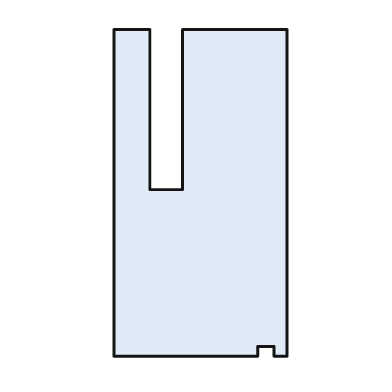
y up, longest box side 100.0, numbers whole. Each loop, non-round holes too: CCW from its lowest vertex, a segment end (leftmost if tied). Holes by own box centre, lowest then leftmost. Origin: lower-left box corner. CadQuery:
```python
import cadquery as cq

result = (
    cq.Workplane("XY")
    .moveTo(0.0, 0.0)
    .lineTo(44.0, 0.0)
    .lineTo(44.0, 3.0)
    .lineTo(49.0, 3.0)
    .lineTo(49.0, 0.0)
    .lineTo(53.0, 0.0)
    .lineTo(53.0, 100.0)
    .lineTo(21.0, 100.0)
    .lineTo(21.0, 51.0)
    .lineTo(11.0, 51.0)
    .lineTo(11.0, 100.0)
    .lineTo(0.0, 100.0)
    .close()
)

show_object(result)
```